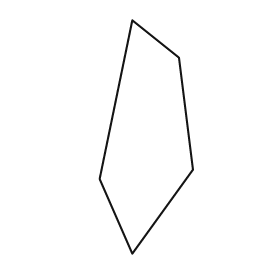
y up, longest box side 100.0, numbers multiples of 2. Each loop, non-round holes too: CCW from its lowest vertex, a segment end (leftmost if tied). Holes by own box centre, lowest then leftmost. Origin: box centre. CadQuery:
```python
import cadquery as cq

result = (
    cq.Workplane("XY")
    .moveTo(-6.0, -50.0)
    .lineTo(20.0, -14.0)
    .lineTo(14.0, 34.0)
    .lineTo(-6.0, 50.0)
    .lineTo(-20.0, -18.0)
    .close()
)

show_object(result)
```